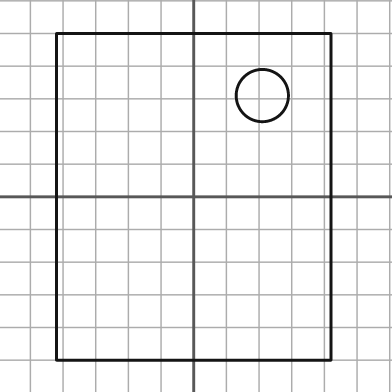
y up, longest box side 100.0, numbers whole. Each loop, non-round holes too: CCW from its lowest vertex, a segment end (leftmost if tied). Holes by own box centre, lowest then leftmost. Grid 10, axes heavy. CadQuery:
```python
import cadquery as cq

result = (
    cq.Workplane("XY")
    .moveTo(-42.0, -50.0)
    .lineTo(42.0, -50.0)
    .lineTo(42.0, 50.0)
    .lineTo(-42.0, 50.0)
    .close()
    .moveTo(21.0, 31.0)
    .circle(8.0)
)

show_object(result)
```